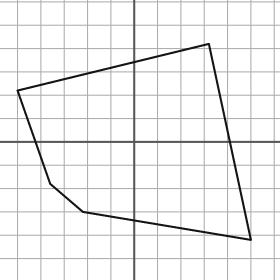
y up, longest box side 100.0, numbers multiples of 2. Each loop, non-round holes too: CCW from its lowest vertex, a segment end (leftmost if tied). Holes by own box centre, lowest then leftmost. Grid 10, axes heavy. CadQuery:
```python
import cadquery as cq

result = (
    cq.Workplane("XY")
    .moveTo(50.0, -42.0)
    .lineTo(32.0, 42.0)
    .lineTo(-50.0, 22.0)
    .lineTo(-36.0, -18.0)
    .lineTo(-22.0, -30.0)
    .close()
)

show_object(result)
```